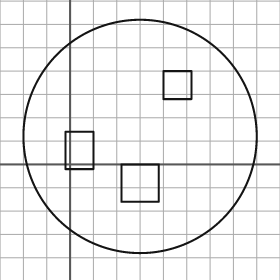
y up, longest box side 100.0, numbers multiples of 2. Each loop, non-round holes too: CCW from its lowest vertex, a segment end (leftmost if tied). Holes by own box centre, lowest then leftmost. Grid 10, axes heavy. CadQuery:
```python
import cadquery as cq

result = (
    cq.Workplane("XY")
    .moveTo(30.0, 12.0)
    .circle(50.0)
    .moveTo(22.0, -16.0)
    .lineTo(38.0, -16.0)
    .lineTo(38.0, 0.0)
    .lineTo(22.0, 0.0)
    .close()
    .moveTo(-2.0, -2.0)
    .lineTo(10.0, -2.0)
    .lineTo(10.0, 14.0)
    .lineTo(-2.0, 14.0)
    .close()
    .moveTo(40.0, 28.0)
    .lineTo(52.0, 28.0)
    .lineTo(52.0, 40.0)
    .lineTo(40.0, 40.0)
    .close()
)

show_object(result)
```